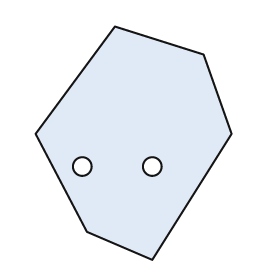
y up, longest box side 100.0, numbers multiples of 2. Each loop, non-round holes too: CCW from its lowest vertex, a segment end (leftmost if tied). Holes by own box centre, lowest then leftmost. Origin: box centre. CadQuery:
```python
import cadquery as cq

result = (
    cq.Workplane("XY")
    .moveTo(8.0, -50.0)
    .lineTo(42.0, 4.0)
    .lineTo(30.0, 38.0)
    .lineTo(-8.0, 50.0)
    .lineTo(-42.0, 4.0)
    .lineTo(-20.0, -38.0)
    .close()
    .moveTo(-22.0, -10.0)
    .circle(4.0)
    .moveTo(8.0, -10.0)
    .circle(4.0)
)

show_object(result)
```